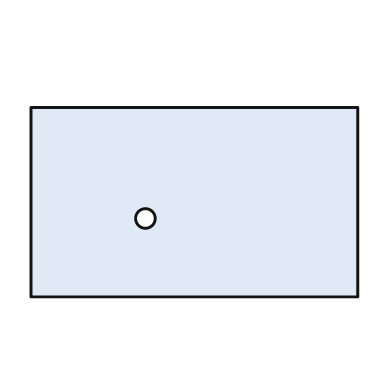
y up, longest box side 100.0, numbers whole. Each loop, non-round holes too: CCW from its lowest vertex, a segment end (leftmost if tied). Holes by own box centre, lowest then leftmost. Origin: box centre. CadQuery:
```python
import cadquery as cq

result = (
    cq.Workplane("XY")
    .moveTo(-50.0, -29.0)
    .lineTo(50.0, -29.0)
    .lineTo(50.0, 29.0)
    .lineTo(-50.0, 29.0)
    .close()
    .moveTo(-15.0, -5.0)
    .circle(3.0)
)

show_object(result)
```